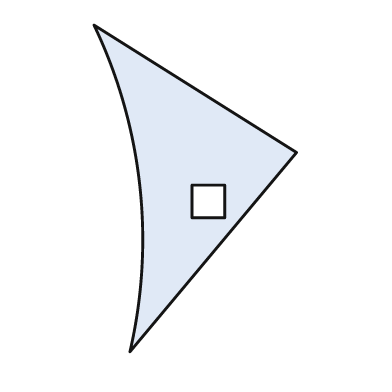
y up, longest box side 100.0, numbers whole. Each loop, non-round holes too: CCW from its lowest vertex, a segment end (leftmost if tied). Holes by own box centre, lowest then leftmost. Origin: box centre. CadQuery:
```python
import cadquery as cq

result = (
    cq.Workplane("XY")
    .moveTo(-20.0, -50.0)
    .lineTo(31.0, 11.0)
    .lineTo(-31.0, 50.0)
    .threePointArc((-17.0, 1.0), (-20.0, -50.0))
    .close()
    .moveTo(-1.0, -9.0)
    .lineTo(9.0, -9.0)
    .lineTo(9.0, 1.0)
    .lineTo(-1.0, 1.0)
    .close()
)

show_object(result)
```